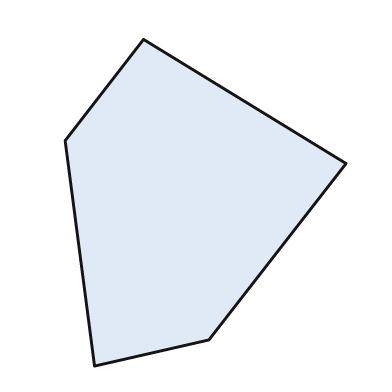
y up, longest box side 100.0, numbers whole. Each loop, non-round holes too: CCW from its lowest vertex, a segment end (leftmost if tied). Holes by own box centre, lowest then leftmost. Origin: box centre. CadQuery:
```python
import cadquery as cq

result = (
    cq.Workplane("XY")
    .moveTo(-34.0, -50.0)
    .lineTo(1.0, -42.0)
    .lineTo(43.0, 12.0)
    .lineTo(-19.0, 50.0)
    .lineTo(-43.0, 19.0)
    .close()
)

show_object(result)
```